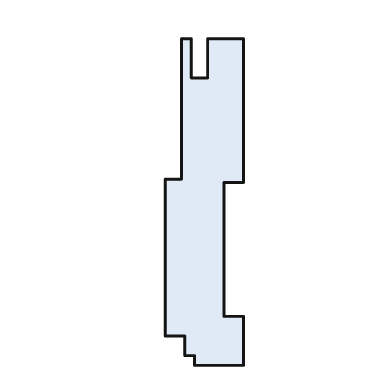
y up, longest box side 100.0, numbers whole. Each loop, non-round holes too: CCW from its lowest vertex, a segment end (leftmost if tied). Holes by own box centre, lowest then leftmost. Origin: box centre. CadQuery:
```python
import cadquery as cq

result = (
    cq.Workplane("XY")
    .moveTo(-3.0, -50.0)
    .lineTo(12.0, -50.0)
    .lineTo(12.0, -35.0)
    .lineTo(6.0, -35.0)
    .lineTo(6.0, 6.0)
    .lineTo(12.0, 6.0)
    .lineTo(12.0, 50.0)
    .lineTo(1.0, 50.0)
    .lineTo(1.0, 38.0)
    .lineTo(-4.0, 38.0)
    .lineTo(-4.0, 50.0)
    .lineTo(-7.0, 50.0)
    .lineTo(-7.0, 7.0)
    .lineTo(-12.0, 7.0)
    .lineTo(-12.0, -41.0)
    .lineTo(-6.0, -41.0)
    .lineTo(-6.0, -47.0)
    .lineTo(-3.0, -47.0)
    .close()
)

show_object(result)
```